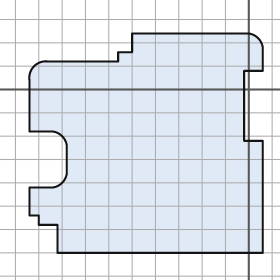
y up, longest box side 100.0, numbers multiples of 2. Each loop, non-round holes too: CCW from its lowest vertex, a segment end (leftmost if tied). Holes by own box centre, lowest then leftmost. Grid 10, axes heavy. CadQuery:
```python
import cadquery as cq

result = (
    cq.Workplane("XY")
    .moveTo(-82.0, -70.0)
    .lineTo(6.0, -70.0)
    .lineTo(6.0, -22.0)
    .lineTo(-2.0, -22.0)
    .lineTo(-2.0, 8.0)
    .lineTo(6.0, 8.0)
    .lineTo(6.0, 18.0)
    .threePointArc((4.0, 22.0), (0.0, 24.0))
    .lineTo(-50.0, 24.0)
    .lineTo(-50.0, 16.0)
    .lineTo(-56.0, 16.0)
    .lineTo(-56.0, 12.0)
    .lineTo(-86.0, 12.0)
    .threePointArc((-92.0, 10.0), (-94.0, 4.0))
    .lineTo(-94.0, -18.0)
    .lineTo(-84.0, -18.0)
    .threePointArc((-80.0, -20.0), (-78.0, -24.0))
    .lineTo(-78.0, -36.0)
    .threePointArc((-80.0, -40.0), (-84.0, -42.0))
    .lineTo(-94.0, -42.0)
    .lineTo(-94.0, -54.0)
    .lineTo(-90.0, -54.0)
    .lineTo(-90.0, -58.0)
    .lineTo(-82.0, -58.0)
    .close()
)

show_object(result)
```